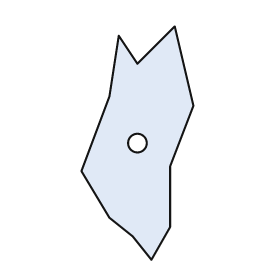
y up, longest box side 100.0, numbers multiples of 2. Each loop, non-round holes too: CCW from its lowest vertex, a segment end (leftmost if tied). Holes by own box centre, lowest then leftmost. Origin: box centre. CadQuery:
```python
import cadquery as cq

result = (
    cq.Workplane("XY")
    .moveTo(6.0, -50.0)
    .lineTo(14.0, -36.0)
    .lineTo(14.0, -10.0)
    .lineTo(24.0, 16.0)
    .lineTo(16.0, 50.0)
    .lineTo(0.0, 34.0)
    .lineTo(-8.0, 46.0)
    .lineTo(-12.0, 20.0)
    .lineTo(-24.0, -12.0)
    .lineTo(-12.0, -32.0)
    .lineTo(-2.0, -40.0)
    .close()
    .moveTo(0.0, 0.0)
    .circle(4.0)
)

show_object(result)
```